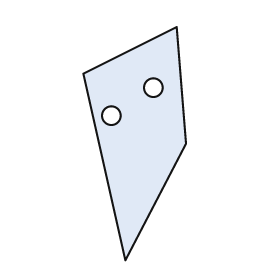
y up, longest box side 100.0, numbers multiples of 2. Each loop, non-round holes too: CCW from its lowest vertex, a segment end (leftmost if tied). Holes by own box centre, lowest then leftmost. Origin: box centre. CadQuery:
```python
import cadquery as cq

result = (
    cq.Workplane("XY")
    .moveTo(-4.0, -50.0)
    .lineTo(22.0, 0.0)
    .lineTo(18.0, 50.0)
    .lineTo(-22.0, 30.0)
    .close()
    .moveTo(-10.0, 12.0)
    .circle(4.0)
    .moveTo(8.0, 24.0)
    .circle(4.0)
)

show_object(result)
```